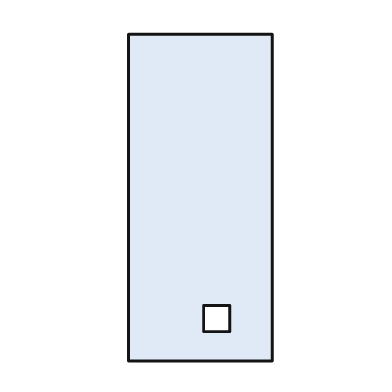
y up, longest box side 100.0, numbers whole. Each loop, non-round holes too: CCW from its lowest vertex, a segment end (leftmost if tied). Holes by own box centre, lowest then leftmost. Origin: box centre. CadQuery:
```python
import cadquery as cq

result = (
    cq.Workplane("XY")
    .moveTo(-22.0, -50.0)
    .lineTo(22.0, -50.0)
    .lineTo(22.0, 50.0)
    .lineTo(-22.0, 50.0)
    .close()
    .moveTo(1.0, -41.0)
    .lineTo(9.0, -41.0)
    .lineTo(9.0, -33.0)
    .lineTo(1.0, -33.0)
    .close()
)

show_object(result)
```